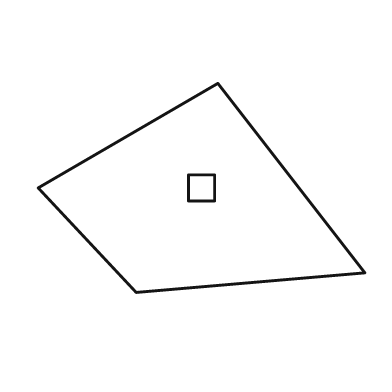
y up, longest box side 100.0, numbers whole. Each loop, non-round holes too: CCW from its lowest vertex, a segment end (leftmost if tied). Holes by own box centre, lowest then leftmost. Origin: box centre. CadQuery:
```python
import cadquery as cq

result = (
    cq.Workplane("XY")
    .moveTo(-20.0, -32.0)
    .lineTo(50.0, -26.0)
    .lineTo(5.0, 32.0)
    .lineTo(-50.0, 0.0)
    .close()
    .moveTo(-4.0, -4.0)
    .lineTo(4.0, -4.0)
    .lineTo(4.0, 4.0)
    .lineTo(-4.0, 4.0)
    .close()
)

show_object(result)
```